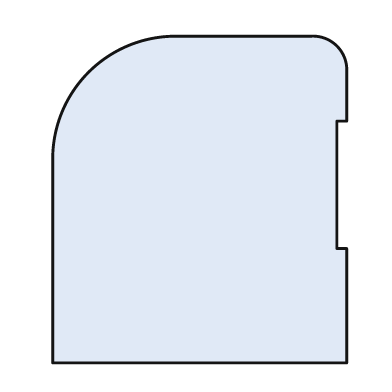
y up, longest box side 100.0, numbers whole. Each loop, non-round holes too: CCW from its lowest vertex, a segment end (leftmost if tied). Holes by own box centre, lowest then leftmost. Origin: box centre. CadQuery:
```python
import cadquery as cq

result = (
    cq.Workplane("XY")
    .moveTo(-45.0, -50.0)
    .lineTo(45.0, -50.0)
    .lineTo(45.0, -15.0)
    .lineTo(42.0, -15.0)
    .lineTo(42.0, 24.0)
    .lineTo(45.0, 24.0)
    .lineTo(45.0, 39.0)
    .threePointArc((42.0, 47.0), (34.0, 50.0))
    .lineTo(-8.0, 50.0)
    .threePointArc((-34.0, 39.0), (-45.0, 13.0))
    .close()
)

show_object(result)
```